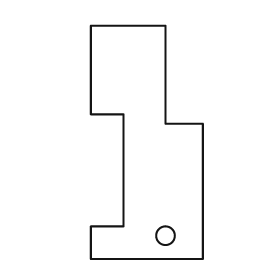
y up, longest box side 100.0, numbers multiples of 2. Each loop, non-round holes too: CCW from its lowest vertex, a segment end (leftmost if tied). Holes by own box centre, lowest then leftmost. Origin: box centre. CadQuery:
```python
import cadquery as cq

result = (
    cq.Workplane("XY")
    .moveTo(-24.0, -50.0)
    .lineTo(24.0, -50.0)
    .lineTo(24.0, 8.0)
    .lineTo(8.0, 8.0)
    .lineTo(8.0, 50.0)
    .lineTo(-24.0, 50.0)
    .lineTo(-24.0, 12.0)
    .lineTo(-10.0, 12.0)
    .lineTo(-10.0, -36.0)
    .lineTo(-24.0, -36.0)
    .close()
    .moveTo(8.0, -40.0)
    .circle(4.0)
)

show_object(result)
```